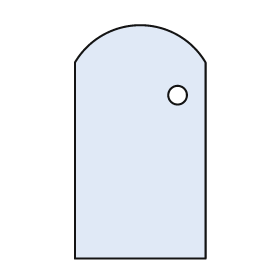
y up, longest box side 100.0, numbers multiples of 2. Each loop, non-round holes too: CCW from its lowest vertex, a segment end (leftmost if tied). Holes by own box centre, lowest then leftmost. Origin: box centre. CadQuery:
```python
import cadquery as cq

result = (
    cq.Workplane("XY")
    .moveTo(-28.0, -50.0)
    .lineTo(28.0, -50.0)
    .lineTo(28.0, 34.0)
    .threePointArc((0.0, 50.0), (-28.0, 34.0))
    .close()
    .moveTo(16.0, 20.0)
    .circle(4.0)
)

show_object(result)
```